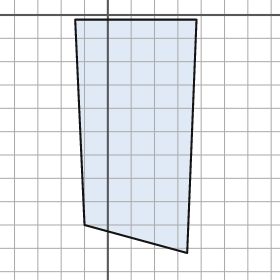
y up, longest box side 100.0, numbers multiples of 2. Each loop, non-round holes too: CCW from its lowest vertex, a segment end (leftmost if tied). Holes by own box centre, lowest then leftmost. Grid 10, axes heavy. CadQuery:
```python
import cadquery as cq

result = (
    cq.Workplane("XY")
    .moveTo(34.0, -102.0)
    .lineTo(38.0, -2.0)
    .lineTo(-14.0, -2.0)
    .lineTo(-10.0, -90.0)
    .close()
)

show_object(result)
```